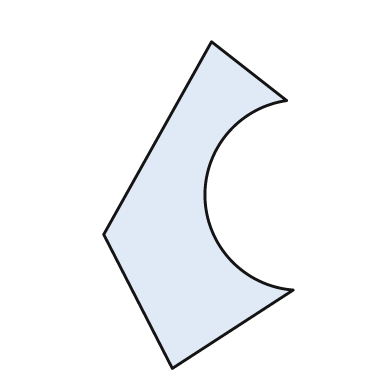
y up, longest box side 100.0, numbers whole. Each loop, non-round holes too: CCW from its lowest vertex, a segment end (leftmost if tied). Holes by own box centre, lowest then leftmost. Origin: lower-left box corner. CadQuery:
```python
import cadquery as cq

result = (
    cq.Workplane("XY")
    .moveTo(21.0, 0.0)
    .lineTo(58.0, 24.0)
    .threePointArc((31.0, 52.0), (56.0, 82.0))
    .lineTo(33.0, 100.0)
    .lineTo(0.0, 41.0)
    .close()
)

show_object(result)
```